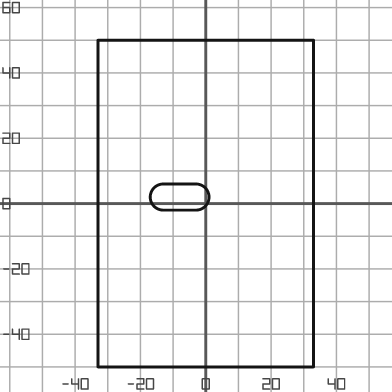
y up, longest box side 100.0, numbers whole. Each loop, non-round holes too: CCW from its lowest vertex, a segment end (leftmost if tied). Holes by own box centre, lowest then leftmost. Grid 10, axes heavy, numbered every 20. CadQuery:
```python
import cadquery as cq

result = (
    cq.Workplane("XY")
    .moveTo(-33.0, -50.0)
    .lineTo(33.0, -50.0)
    .lineTo(33.0, 50.0)
    .lineTo(-33.0, 50.0)
    .close()
    .moveTo(-13.0, -2.0)
    .lineTo(-3.0, -2.0)
    .threePointArc((1.0, 2.0), (-3.0, 6.0))
    .lineTo(-13.0, 6.0)
    .threePointArc((-17.0, 2.0), (-13.0, -2.0))
    .close()
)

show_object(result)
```